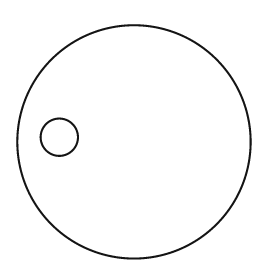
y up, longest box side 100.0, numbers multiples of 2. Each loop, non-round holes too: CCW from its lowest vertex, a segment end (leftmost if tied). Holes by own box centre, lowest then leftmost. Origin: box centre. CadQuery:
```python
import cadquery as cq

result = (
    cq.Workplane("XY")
    .moveTo(0.0, 0.0)
    .circle(50.0)
    .moveTo(-32.0, 2.0)
    .circle(8.0)
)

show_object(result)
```